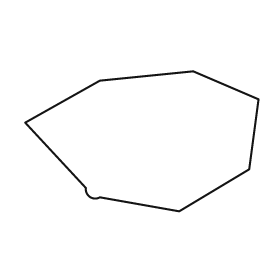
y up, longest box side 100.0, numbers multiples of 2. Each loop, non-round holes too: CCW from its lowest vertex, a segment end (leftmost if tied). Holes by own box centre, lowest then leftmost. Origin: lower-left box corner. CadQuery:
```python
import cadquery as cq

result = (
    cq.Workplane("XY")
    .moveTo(66.0, 0.0)
    .lineTo(96.0, 18.0)
    .lineTo(100.0, 48.0)
    .lineTo(72.0, 60.0)
    .lineTo(32.0, 56.0)
    .lineTo(0.0, 38.0)
    .lineTo(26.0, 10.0)
    .threePointArc((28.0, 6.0), (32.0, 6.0))
    .close()
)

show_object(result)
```